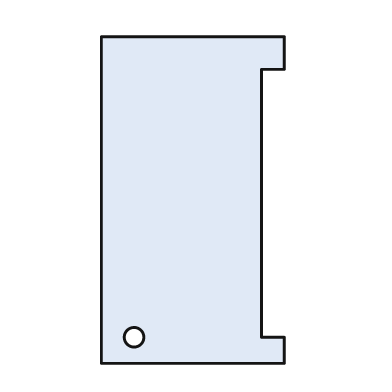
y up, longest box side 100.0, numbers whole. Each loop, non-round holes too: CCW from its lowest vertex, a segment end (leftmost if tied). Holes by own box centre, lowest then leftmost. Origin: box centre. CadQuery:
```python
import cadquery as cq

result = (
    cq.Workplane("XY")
    .moveTo(-28.0, -50.0)
    .lineTo(28.0, -50.0)
    .lineTo(28.0, -42.0)
    .lineTo(21.0, -42.0)
    .lineTo(21.0, 40.0)
    .lineTo(28.0, 40.0)
    .lineTo(28.0, 50.0)
    .lineTo(-28.0, 50.0)
    .close()
    .moveTo(-18.0, -42.0)
    .circle(3.0)
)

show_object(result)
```